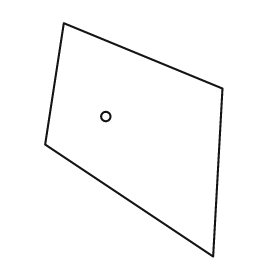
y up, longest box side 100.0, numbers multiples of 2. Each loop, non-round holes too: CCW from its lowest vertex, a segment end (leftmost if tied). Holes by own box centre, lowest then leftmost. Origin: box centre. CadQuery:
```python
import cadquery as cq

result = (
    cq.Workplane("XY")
    .moveTo(34.0, -50.0)
    .lineTo(38.0, 22.0)
    .lineTo(-30.0, 50.0)
    .lineTo(-38.0, -2.0)
    .close()
    .moveTo(-12.0, 10.0)
    .circle(2.0)
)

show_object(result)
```